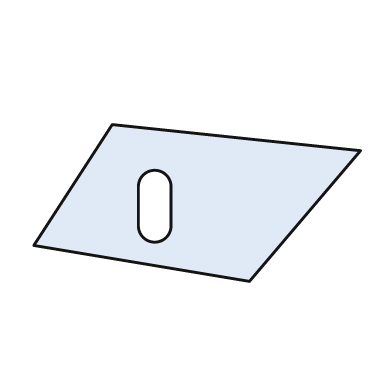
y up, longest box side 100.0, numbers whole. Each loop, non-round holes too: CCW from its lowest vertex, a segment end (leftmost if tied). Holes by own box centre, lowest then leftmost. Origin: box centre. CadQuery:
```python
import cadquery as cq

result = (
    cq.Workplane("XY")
    .moveTo(16.0, -24.0)
    .lineTo(50.0, 16.0)
    .lineTo(-26.0, 24.0)
    .lineTo(-50.0, -13.0)
    .close()
    .moveTo(-18.0, -7.0)
    .threePointArc((-13.0, -12.0), (-8.0, -7.0))
    .lineTo(-8.0, 5.0)
    .threePointArc((-13.0, 10.0), (-18.0, 5.0))
    .close()
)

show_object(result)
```